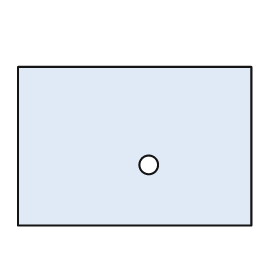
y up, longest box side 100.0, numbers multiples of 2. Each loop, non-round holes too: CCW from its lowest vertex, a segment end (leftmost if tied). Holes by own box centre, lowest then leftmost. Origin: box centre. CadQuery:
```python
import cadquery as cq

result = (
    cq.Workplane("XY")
    .moveTo(-50.0, -34.0)
    .lineTo(50.0, -34.0)
    .lineTo(50.0, 34.0)
    .lineTo(-50.0, 34.0)
    .close()
    .moveTo(6.0, -8.0)
    .circle(4.0)
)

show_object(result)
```